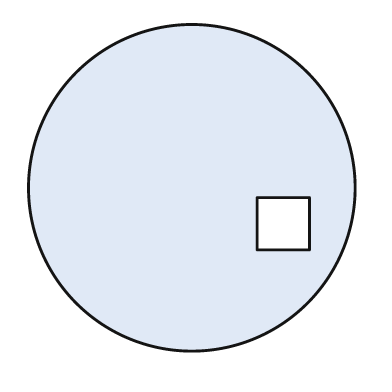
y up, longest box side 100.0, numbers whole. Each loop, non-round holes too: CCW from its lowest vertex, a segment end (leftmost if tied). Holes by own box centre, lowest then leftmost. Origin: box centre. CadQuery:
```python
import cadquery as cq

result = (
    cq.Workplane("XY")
    .moveTo(0.0, 0.0)
    .circle(50.0)
    .moveTo(20.0, -19.0)
    .lineTo(36.0, -19.0)
    .lineTo(36.0, -3.0)
    .lineTo(20.0, -3.0)
    .close()
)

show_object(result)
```